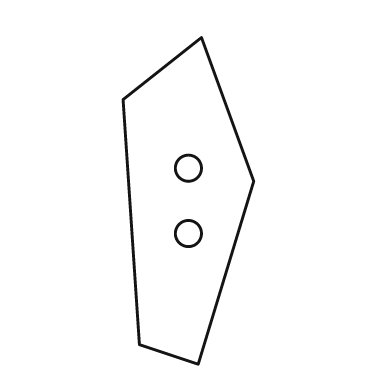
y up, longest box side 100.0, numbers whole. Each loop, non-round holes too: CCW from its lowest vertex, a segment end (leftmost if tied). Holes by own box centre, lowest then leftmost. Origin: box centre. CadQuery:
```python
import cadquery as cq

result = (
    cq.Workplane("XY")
    .moveTo(3.0, -50.0)
    .lineTo(20.0, 6.0)
    .lineTo(4.0, 50.0)
    .lineTo(-20.0, 31.0)
    .lineTo(-15.0, -44.0)
    .close()
    .moveTo(0.0, -10.0)
    .circle(4.0)
    .moveTo(0.0, 10.0)
    .circle(4.0)
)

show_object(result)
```